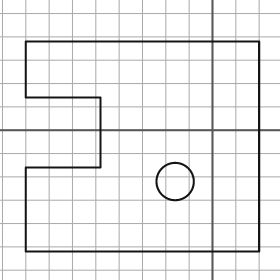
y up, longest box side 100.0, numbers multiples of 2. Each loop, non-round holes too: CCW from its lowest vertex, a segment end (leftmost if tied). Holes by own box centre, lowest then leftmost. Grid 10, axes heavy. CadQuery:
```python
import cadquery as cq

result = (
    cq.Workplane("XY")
    .moveTo(-80.0, -52.0)
    .lineTo(20.0, -52.0)
    .lineTo(20.0, 38.0)
    .lineTo(-80.0, 38.0)
    .lineTo(-80.0, 14.0)
    .lineTo(-48.0, 14.0)
    .lineTo(-48.0, -16.0)
    .lineTo(-80.0, -16.0)
    .close()
    .moveTo(-16.0, -22.0)
    .circle(8.0)
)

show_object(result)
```